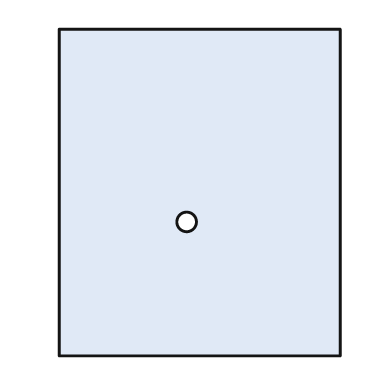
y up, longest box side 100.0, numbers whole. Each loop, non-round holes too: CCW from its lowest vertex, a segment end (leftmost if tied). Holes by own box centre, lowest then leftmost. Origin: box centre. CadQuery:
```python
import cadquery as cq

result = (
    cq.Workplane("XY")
    .moveTo(-43.0, -50.0)
    .lineTo(43.0, -50.0)
    .lineTo(43.0, 50.0)
    .lineTo(-43.0, 50.0)
    .close()
    .moveTo(-4.0, -9.0)
    .circle(3.0)
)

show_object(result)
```